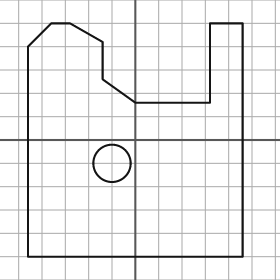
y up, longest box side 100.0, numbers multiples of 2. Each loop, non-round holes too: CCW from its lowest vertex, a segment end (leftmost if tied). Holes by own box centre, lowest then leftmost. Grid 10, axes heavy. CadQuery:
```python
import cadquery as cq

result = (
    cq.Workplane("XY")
    .moveTo(-46.0, -50.0)
    .lineTo(46.0, -50.0)
    .lineTo(46.0, 50.0)
    .lineTo(32.0, 50.0)
    .lineTo(32.0, 16.0)
    .lineTo(0.0, 16.0)
    .lineTo(-14.0, 26.0)
    .lineTo(-14.0, 42.0)
    .lineTo(-28.0, 50.0)
    .lineTo(-36.0, 50.0)
    .lineTo(-46.0, 40.0)
    .close()
    .moveTo(-10.0, -10.0)
    .circle(8.0)
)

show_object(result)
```